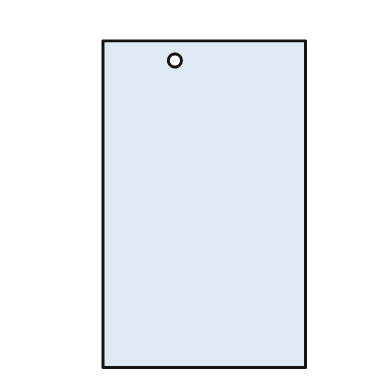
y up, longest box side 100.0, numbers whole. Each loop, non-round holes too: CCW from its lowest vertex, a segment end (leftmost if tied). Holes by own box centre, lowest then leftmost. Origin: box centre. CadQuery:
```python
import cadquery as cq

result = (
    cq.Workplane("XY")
    .moveTo(-31.0, -50.0)
    .lineTo(31.0, -50.0)
    .lineTo(31.0, 50.0)
    .lineTo(-31.0, 50.0)
    .close()
    .moveTo(-9.0, 44.0)
    .circle(2.0)
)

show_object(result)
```